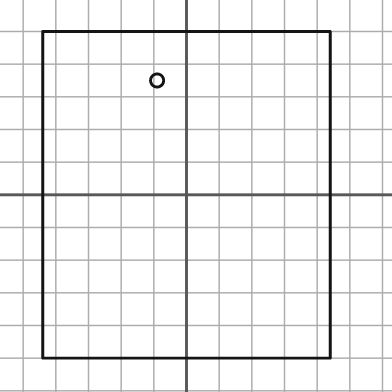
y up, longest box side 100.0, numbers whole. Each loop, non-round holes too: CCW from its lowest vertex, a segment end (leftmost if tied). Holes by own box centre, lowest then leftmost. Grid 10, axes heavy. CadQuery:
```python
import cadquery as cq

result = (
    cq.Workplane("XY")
    .moveTo(-44.0, -50.0)
    .lineTo(44.0, -50.0)
    .lineTo(44.0, 50.0)
    .lineTo(-44.0, 50.0)
    .close()
    .moveTo(-9.0, 35.0)
    .circle(2.0)
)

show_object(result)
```